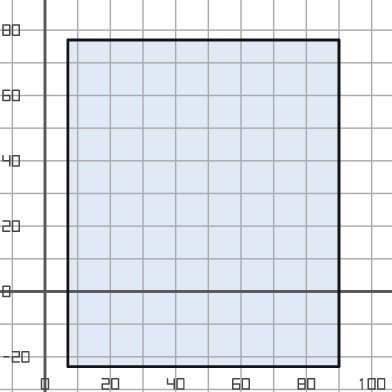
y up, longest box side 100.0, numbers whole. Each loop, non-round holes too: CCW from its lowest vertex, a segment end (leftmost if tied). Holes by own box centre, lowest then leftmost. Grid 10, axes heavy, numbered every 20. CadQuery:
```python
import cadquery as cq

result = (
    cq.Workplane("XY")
    .moveTo(7.0, -23.0)
    .lineTo(90.0, -23.0)
    .lineTo(90.0, 77.0)
    .lineTo(7.0, 77.0)
    .close()
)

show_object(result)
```